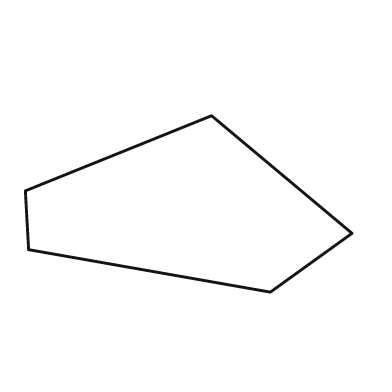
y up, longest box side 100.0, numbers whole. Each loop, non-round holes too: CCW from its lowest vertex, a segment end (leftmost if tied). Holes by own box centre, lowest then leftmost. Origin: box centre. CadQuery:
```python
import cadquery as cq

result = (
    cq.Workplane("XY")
    .moveTo(25.0, -27.0)
    .lineTo(50.0, -9.0)
    .lineTo(7.0, 27.0)
    .lineTo(-50.0, 4.0)
    .lineTo(-49.0, -14.0)
    .close()
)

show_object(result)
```